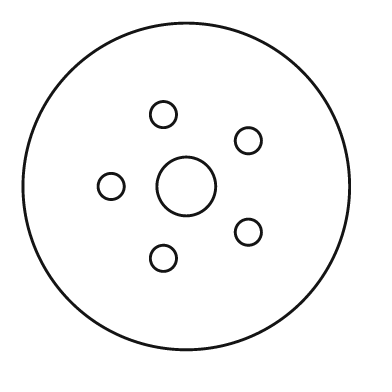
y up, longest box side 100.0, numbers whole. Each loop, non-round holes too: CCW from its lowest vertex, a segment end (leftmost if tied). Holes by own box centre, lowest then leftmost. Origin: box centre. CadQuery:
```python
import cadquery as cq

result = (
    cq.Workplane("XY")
    .moveTo(0.0, 0.0)
    .circle(50.0)
    .moveTo(-7.0, -22.0)
    .circle(4.0)
    .moveTo(19.0, -14.0)
    .circle(4.0)
    .moveTo(-23.0, 0.0)
    .circle(4.0)
    .moveTo(0.0, 0.0)
    .circle(9.0)
    .moveTo(19.0, 14.0)
    .circle(4.0)
    .moveTo(-7.0, 22.0)
    .circle(4.0)
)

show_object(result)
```